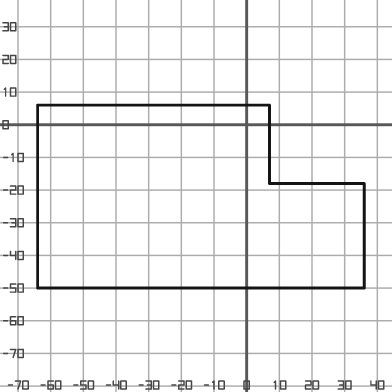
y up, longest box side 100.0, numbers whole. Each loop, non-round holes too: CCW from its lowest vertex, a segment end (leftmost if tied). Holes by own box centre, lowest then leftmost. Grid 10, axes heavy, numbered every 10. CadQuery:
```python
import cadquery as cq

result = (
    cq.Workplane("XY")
    .moveTo(-64.0, -50.0)
    .lineTo(36.0, -50.0)
    .lineTo(36.0, -18.0)
    .lineTo(7.0, -18.0)
    .lineTo(7.0, 6.0)
    .lineTo(-64.0, 6.0)
    .close()
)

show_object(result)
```